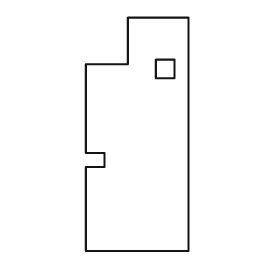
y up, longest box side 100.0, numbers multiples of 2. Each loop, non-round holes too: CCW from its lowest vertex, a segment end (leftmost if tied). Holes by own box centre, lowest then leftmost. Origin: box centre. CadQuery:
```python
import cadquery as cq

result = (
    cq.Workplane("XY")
    .moveTo(-22.0, -50.0)
    .lineTo(22.0, -50.0)
    .lineTo(22.0, 50.0)
    .lineTo(-4.0, 50.0)
    .lineTo(-4.0, 30.0)
    .lineTo(-22.0, 30.0)
    .lineTo(-22.0, -8.0)
    .lineTo(-14.0, -8.0)
    .lineTo(-14.0, -14.0)
    .lineTo(-22.0, -14.0)
    .close()
    .moveTo(8.0, 24.0)
    .lineTo(16.0, 24.0)
    .lineTo(16.0, 32.0)
    .lineTo(8.0, 32.0)
    .close()
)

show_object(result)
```